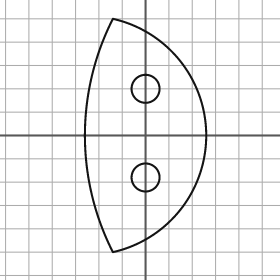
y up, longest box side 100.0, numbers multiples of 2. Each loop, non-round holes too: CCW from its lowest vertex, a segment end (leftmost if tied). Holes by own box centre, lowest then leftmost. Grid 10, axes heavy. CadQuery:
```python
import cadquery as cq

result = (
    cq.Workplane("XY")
    .moveTo(-14.0, -50.0)
    .threePointArc((26.0, 0.0), (-14.0, 50.0))
    .threePointArc((-26.0, 0.0), (-14.0, -50.0))
    .close()
    .moveTo(0.0, -18.0)
    .circle(6.0)
    .moveTo(0.0, 20.0)
    .circle(6.0)
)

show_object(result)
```